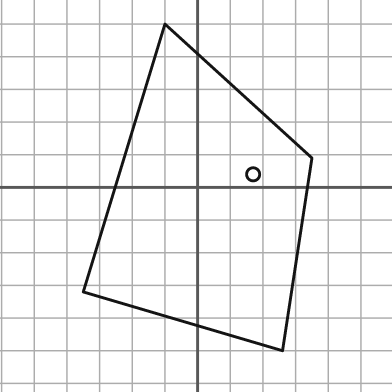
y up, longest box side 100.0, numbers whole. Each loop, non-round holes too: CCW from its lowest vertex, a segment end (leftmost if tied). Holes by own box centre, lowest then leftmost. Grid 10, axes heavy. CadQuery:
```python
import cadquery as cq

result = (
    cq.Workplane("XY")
    .moveTo(26.0, -50.0)
    .lineTo(35.0, 9.0)
    .lineTo(-10.0, 50.0)
    .lineTo(-35.0, -32.0)
    .close()
    .moveTo(17.0, 4.0)
    .circle(2.0)
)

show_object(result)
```